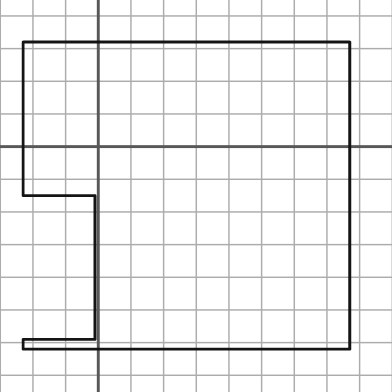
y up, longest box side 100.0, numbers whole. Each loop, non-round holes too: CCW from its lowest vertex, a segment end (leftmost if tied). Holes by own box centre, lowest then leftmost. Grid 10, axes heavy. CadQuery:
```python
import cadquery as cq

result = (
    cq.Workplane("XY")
    .moveTo(-23.0, -62.0)
    .lineTo(77.0, -62.0)
    .lineTo(77.0, 32.0)
    .lineTo(-23.0, 32.0)
    .lineTo(-23.0, -15.0)
    .lineTo(-1.0, -15.0)
    .lineTo(-1.0, -59.0)
    .lineTo(-23.0, -59.0)
    .close()
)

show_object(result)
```